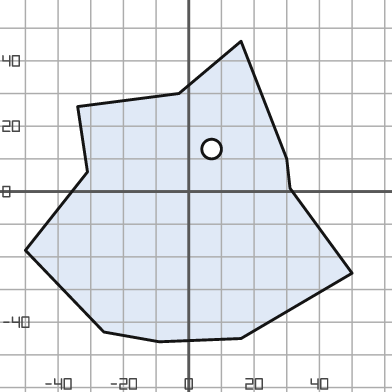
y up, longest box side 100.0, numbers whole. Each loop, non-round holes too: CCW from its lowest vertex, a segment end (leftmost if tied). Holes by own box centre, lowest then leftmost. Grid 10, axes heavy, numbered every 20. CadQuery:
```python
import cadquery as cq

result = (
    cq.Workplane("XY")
    .moveTo(-9.0, -46.0)
    .lineTo(16.0, -45.0)
    .lineTo(50.0, -25.0)
    .lineTo(31.0, 1.0)
    .lineTo(30.0, 10.0)
    .lineTo(16.0, 46.0)
    .lineTo(-3.0, 30.0)
    .lineTo(-34.0, 26.0)
    .lineTo(-31.0, 6.0)
    .lineTo(-50.0, -18.0)
    .lineTo(-26.0, -43.0)
    .close()
    .moveTo(7.0, 13.0)
    .circle(3.0)
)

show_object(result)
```